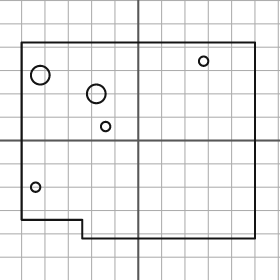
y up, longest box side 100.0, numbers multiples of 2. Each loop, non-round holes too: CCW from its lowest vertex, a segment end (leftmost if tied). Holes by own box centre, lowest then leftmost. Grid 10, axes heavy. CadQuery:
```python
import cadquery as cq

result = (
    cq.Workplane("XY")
    .moveTo(-24.0, -42.0)
    .lineTo(50.0, -42.0)
    .lineTo(50.0, 42.0)
    .lineTo(-50.0, 42.0)
    .lineTo(-50.0, -34.0)
    .lineTo(-24.0, -34.0)
    .close()
    .moveTo(-44.0, -20.0)
    .circle(2.0)
    .moveTo(-14.0, 6.0)
    .circle(2.0)
    .moveTo(-18.0, 20.0)
    .circle(4.0)
    .moveTo(-42.0, 28.0)
    .circle(4.0)
    .moveTo(28.0, 34.0)
    .circle(2.0)
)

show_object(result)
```